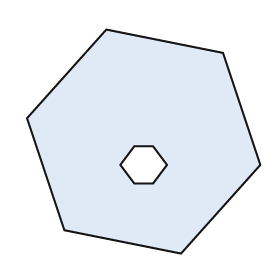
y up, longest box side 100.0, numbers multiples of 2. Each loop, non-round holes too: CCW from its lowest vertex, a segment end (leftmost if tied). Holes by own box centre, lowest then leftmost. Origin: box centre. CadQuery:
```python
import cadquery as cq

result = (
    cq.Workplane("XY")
    .moveTo(16.0, -48.0)
    .lineTo(50.0, -10.0)
    .lineTo(34.0, 38.0)
    .lineTo(-16.0, 48.0)
    .lineTo(-50.0, 10.0)
    .lineTo(-34.0, -38.0)
    .close()
    .moveTo(-4.0, -18.0)
    .lineTo(4.0, -18.0)
    .lineTo(10.0, -10.0)
    .lineTo(4.0, -2.0)
    .lineTo(-4.0, -2.0)
    .lineTo(-10.0, -10.0)
    .close()
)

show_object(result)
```